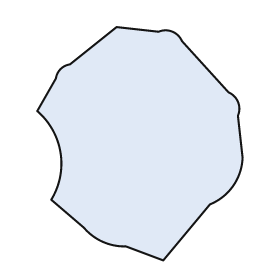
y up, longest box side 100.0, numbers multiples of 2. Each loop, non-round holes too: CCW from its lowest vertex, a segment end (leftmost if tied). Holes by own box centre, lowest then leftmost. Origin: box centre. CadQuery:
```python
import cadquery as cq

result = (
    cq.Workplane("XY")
    .moveTo(10.0, -50.0)
    .lineTo(30.0, -26.0)
    .threePointArc((40.0, -18.0), (44.0, -6.0))
    .lineTo(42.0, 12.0)
    .threePointArc((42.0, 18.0), (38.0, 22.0))
    .lineTo(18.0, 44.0)
    .threePointArc((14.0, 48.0), (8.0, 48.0))
    .lineTo(-10.0, 50.0)
    .lineTo(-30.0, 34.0)
    .threePointArc((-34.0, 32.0), (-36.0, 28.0))
    .lineTo(-44.0, 14.0)
    .threePointArc((-34.0, -4.0), (-38.0, -24.0))
    .lineTo(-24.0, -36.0)
    .threePointArc((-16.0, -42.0), (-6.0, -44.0))
    .close()
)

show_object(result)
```